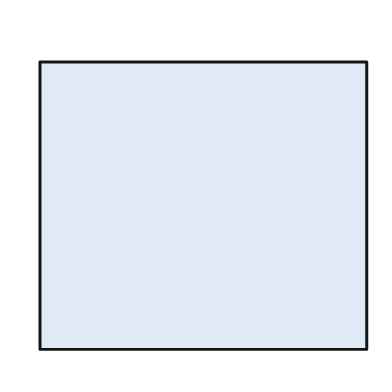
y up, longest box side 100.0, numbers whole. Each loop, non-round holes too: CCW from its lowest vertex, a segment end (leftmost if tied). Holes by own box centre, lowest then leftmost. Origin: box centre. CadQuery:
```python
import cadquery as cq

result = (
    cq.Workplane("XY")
    .moveTo(-50.0, -44.0)
    .lineTo(50.0, -44.0)
    .lineTo(50.0, 44.0)
    .lineTo(-50.0, 44.0)
    .close()
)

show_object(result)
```